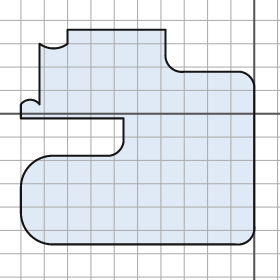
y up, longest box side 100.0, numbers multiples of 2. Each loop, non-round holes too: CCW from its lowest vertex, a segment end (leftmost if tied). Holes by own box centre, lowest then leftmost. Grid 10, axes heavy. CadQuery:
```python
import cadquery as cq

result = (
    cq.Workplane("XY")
    .moveTo(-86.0, -56.0)
    .lineTo(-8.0, -56.0)
    .threePointArc((-2.0, -54.0), (0.0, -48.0))
    .lineTo(0.0, 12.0)
    .threePointArc((-2.0, 16.0), (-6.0, 18.0))
    .lineTo(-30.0, 18.0)
    .threePointArc((-36.0, 20.0), (-38.0, 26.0))
    .lineTo(-38.0, 36.0)
    .lineTo(-80.0, 36.0)
    .lineTo(-80.0, 30.0)
    .threePointArc((-86.0, 28.0), (-92.0, 30.0))
    .lineTo(-92.0, 4.0)
    .threePointArc((-96.0, 6.0), (-100.0, 4.0))
    .lineTo(-100.0, -2.0)
    .lineTo(-56.0, -2.0)
    .lineTo(-56.0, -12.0)
    .threePointArc((-58.0, -16.0), (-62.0, -18.0))
    .lineTo(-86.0, -18.0)
    .threePointArc((-96.0, -22.0), (-100.0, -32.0))
    .lineTo(-100.0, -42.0)
    .threePointArc((-96.0, -52.0), (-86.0, -56.0))
    .close()
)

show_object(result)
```